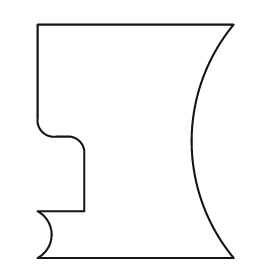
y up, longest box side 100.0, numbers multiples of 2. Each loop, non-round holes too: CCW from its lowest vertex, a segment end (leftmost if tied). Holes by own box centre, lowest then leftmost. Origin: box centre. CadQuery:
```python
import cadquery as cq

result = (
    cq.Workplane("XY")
    .moveTo(-42.0, -50.0)
    .lineTo(42.0, -50.0)
    .threePointArc((24.0, 0.0), (42.0, 50.0))
    .lineTo(-42.0, 50.0)
    .lineTo(-42.0, 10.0)
    .threePointArc((-40.0, 4.0), (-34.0, 2.0))
    .lineTo(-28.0, 2.0)
    .threePointArc((-24.0, 0.0), (-22.0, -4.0))
    .lineTo(-22.0, -30.0)
    .lineTo(-42.0, -30.0)
    .threePointArc((-36.0, -40.0), (-42.0, -50.0))
    .close()
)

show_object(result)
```